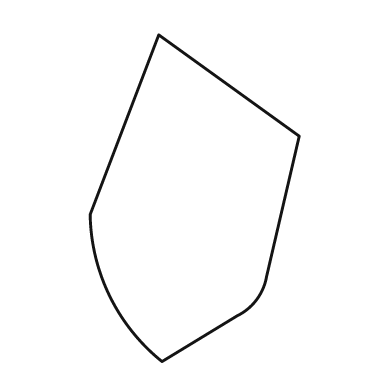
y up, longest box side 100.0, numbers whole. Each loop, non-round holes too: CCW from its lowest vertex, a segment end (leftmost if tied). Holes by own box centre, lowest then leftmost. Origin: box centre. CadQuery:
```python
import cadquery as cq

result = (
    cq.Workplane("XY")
    .moveTo(-10.0, -50.0)
    .lineTo(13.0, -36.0)
    .threePointArc((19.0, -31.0), (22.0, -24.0))
    .lineTo(32.0, 19.0)
    .lineTo(-11.0, 50.0)
    .lineTo(-32.0, -5.0)
    .threePointArc((-26.0, -30.0), (-10.0, -50.0))
    .close()
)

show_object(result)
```